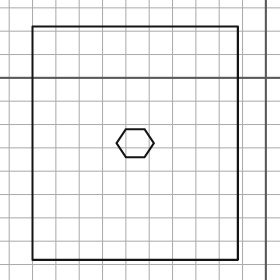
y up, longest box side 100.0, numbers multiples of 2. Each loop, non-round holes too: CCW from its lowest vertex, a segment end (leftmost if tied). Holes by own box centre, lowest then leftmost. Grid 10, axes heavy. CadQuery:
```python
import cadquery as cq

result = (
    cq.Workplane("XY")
    .moveTo(-100.0, -78.0)
    .lineTo(-12.0, -78.0)
    .lineTo(-12.0, 22.0)
    .lineTo(-100.0, 22.0)
    .close()
    .moveTo(-60.0, -34.0)
    .lineTo(-52.0, -34.0)
    .lineTo(-48.0, -28.0)
    .lineTo(-52.0, -22.0)
    .lineTo(-60.0, -22.0)
    .lineTo(-64.0, -28.0)
    .close()
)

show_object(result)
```